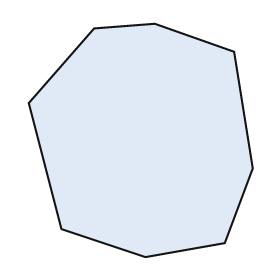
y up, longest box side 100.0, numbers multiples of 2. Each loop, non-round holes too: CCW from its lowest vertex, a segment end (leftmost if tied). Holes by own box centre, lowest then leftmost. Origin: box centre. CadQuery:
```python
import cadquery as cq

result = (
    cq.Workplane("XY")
    .moveTo(2.0, -50.0)
    .lineTo(36.0, -44.0)
    .lineTo(48.0, -12.0)
    .lineTo(40.0, 38.0)
    .lineTo(6.0, 50.0)
    .lineTo(-20.0, 48.0)
    .lineTo(-48.0, 16.0)
    .lineTo(-34.0, -38.0)
    .close()
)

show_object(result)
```